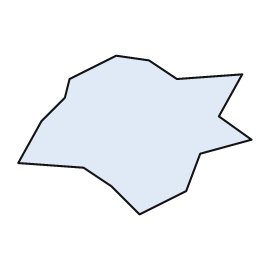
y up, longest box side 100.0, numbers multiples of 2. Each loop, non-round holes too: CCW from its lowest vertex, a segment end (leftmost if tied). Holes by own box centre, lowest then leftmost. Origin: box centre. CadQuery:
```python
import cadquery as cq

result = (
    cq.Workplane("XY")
    .moveTo(2.0, -34.0)
    .lineTo(22.0, -24.0)
    .lineTo(28.0, -8.0)
    .lineTo(50.0, -2.0)
    .lineTo(36.0, 8.0)
    .lineTo(46.0, 26.0)
    .lineTo(18.0, 24.0)
    .lineTo(6.0, 32.0)
    .lineTo(-8.0, 34.0)
    .lineTo(-28.0, 24.0)
    .lineTo(-30.0, 16.0)
    .lineTo(-40.0, 6.0)
    .lineTo(-50.0, -12.0)
    .lineTo(-22.0, -14.0)
    .lineTo(-10.0, -22.0)
    .close()
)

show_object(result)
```